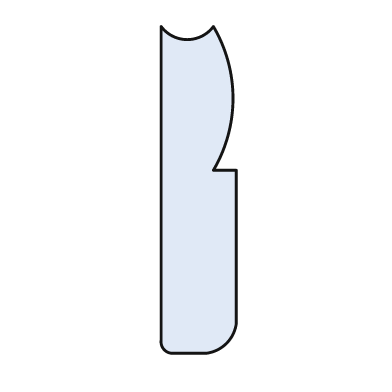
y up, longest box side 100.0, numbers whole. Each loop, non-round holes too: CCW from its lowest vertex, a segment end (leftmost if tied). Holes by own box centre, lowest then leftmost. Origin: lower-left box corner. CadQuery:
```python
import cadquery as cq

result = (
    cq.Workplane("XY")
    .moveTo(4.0, 0.0)
    .lineTo(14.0, 0.0)
    .threePointArc((20.0, 3.0), (23.0, 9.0))
    .lineTo(23.0, 56.0)
    .lineTo(16.0, 56.0)
    .threePointArc((22.0, 78.0), (16.0, 100.0))
    .threePointArc((8.0, 96.0), (0.0, 100.0))
    .lineTo(0.0, 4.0)
    .threePointArc((1.0, 1.0), (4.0, 0.0))
    .close()
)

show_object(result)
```